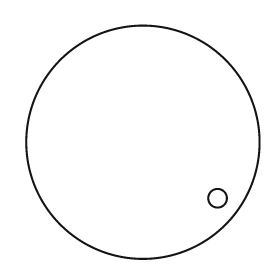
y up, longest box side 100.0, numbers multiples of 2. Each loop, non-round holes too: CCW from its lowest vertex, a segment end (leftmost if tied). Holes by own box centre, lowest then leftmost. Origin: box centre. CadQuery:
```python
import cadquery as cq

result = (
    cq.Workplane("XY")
    .moveTo(0.0, 0.0)
    .circle(50.0)
    .moveTo(32.0, -24.0)
    .circle(4.0)
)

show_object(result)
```